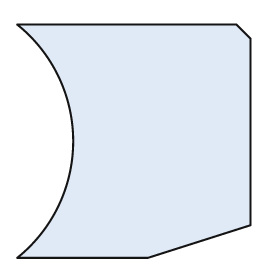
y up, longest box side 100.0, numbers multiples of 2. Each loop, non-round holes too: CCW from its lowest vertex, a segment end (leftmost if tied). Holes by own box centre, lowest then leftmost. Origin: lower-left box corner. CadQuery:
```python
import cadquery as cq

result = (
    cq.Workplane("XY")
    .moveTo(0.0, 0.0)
    .lineTo(56.0, 0.0)
    .lineTo(100.0, 14.0)
    .lineTo(100.0, 94.0)
    .lineTo(94.0, 100.0)
    .lineTo(0.0, 100.0)
    .threePointArc((24.0, 50.0), (0.0, 0.0))
    .close()
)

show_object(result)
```